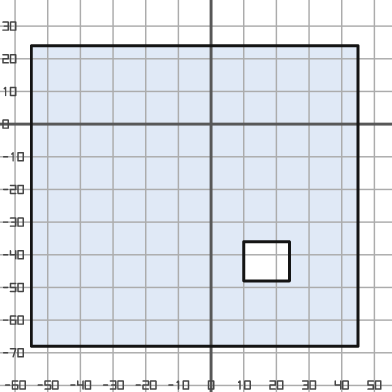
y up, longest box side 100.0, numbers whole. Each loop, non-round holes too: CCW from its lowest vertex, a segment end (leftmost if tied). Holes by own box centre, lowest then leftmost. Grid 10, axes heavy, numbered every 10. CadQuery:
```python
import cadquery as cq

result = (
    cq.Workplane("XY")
    .moveTo(-55.0, -68.0)
    .lineTo(45.0, -68.0)
    .lineTo(45.0, 24.0)
    .lineTo(-55.0, 24.0)
    .close()
    .moveTo(10.0, -48.0)
    .lineTo(24.0, -48.0)
    .lineTo(24.0, -36.0)
    .lineTo(10.0, -36.0)
    .close()
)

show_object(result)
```